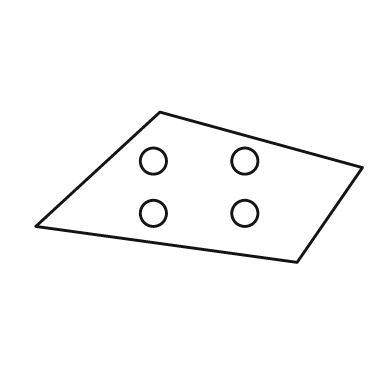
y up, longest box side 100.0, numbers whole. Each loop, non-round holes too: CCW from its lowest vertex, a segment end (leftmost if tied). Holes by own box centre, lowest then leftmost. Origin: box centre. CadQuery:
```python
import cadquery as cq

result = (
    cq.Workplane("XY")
    .moveTo(30.0, -23.0)
    .lineTo(50.0, 6.0)
    .lineTo(-12.0, 23.0)
    .lineTo(-50.0, -12.0)
    .close()
    .moveTo(-14.0, -8.0)
    .circle(4.0)
    .moveTo(14.0, -8.0)
    .circle(4.0)
    .moveTo(-14.0, 8.0)
    .circle(4.0)
    .moveTo(14.0, 8.0)
    .circle(4.0)
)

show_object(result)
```